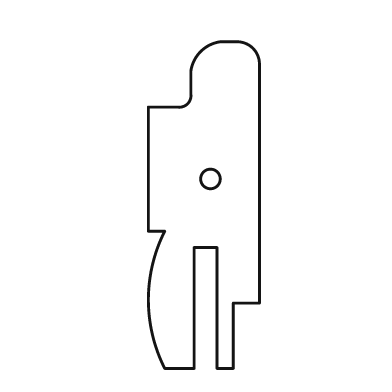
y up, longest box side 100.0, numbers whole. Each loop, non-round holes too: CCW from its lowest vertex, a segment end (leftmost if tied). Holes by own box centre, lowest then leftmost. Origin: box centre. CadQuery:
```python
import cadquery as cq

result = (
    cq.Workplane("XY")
    .moveTo(-12.0, -50.0)
    .lineTo(-3.0, -50.0)
    .lineTo(-3.0, -13.0)
    .lineTo(4.0, -13.0)
    .lineTo(4.0, -50.0)
    .lineTo(9.0, -50.0)
    .lineTo(9.0, -30.0)
    .lineTo(17.0, -30.0)
    .lineTo(17.0, 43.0)
    .threePointArc((15.0, 48.0), (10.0, 50.0))
    .lineTo(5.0, 50.0)
    .threePointArc((-1.0, 47.0), (-4.0, 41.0))
    .lineTo(-4.0, 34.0)
    .threePointArc((-5.0, 31.0), (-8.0, 30.0))
    .lineTo(-17.0, 30.0)
    .lineTo(-17.0, -8.0)
    .lineTo(-12.0, -8.0)
    .threePointArc((-17.0, -29.0), (-12.0, -50.0))
    .close()
    .moveTo(2.0, 8.0)
    .circle(3.0)
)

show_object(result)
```